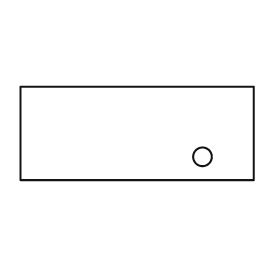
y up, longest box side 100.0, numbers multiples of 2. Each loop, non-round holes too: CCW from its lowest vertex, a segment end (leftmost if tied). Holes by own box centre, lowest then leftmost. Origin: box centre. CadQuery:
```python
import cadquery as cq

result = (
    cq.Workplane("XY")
    .moveTo(-50.0, -20.0)
    .lineTo(50.0, -20.0)
    .lineTo(50.0, 20.0)
    .lineTo(-50.0, 20.0)
    .close()
    .moveTo(28.0, -10.0)
    .circle(4.0)
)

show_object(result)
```